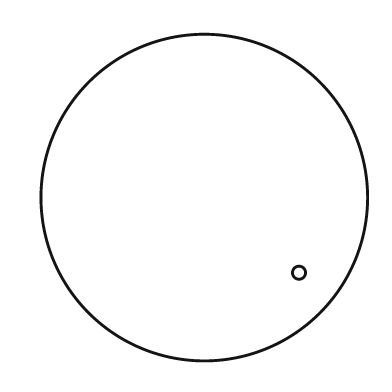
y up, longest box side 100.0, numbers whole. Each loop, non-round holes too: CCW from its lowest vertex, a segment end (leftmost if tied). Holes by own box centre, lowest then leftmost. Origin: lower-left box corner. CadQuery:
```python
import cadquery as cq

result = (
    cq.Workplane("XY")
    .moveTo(50.0, 50.0)
    .circle(50.0)
    .moveTo(79.0, 27.0)
    .circle(2.0)
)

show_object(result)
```